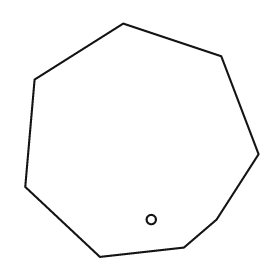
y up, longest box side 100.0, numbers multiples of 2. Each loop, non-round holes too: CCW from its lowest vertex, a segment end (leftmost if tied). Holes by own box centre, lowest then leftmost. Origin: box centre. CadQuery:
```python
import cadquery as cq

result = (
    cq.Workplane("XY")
    .moveTo(-18.0, -50.0)
    .lineTo(18.0, -46.0)
    .lineTo(32.0, -34.0)
    .lineTo(50.0, -6.0)
    .lineTo(34.0, 36.0)
    .lineTo(-8.0, 50.0)
    .lineTo(-46.0, 26.0)
    .lineTo(-50.0, -20.0)
    .close()
    .moveTo(4.0, -34.0)
    .circle(2.0)
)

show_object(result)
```